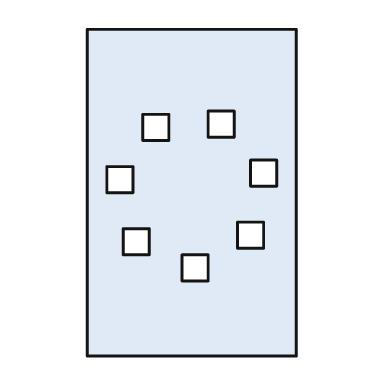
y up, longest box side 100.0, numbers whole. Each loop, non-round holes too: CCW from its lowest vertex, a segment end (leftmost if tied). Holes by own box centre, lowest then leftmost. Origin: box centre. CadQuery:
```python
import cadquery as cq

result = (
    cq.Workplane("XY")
    .moveTo(-32.0, -50.0)
    .lineTo(32.0, -50.0)
    .lineTo(32.0, 50.0)
    .lineTo(-32.0, 50.0)
    .close()
    .moveTo(-3.0, -27.0)
    .lineTo(5.0, -27.0)
    .lineTo(5.0, -19.0)
    .lineTo(-3.0, -19.0)
    .close()
    .moveTo(-21.0, -19.0)
    .lineTo(-13.0, -19.0)
    .lineTo(-13.0, -11.0)
    .lineTo(-21.0, -11.0)
    .close()
    .moveTo(14.0, -17.0)
    .lineTo(22.0, -17.0)
    .lineTo(22.0, -9.0)
    .lineTo(14.0, -9.0)
    .close()
    .moveTo(-26.0, 0.0)
    .lineTo(-18.0, 0.0)
    .lineTo(-18.0, 8.0)
    .lineTo(-26.0, 8.0)
    .close()
    .moveTo(18.0, 2.0)
    .lineTo(26.0, 2.0)
    .lineTo(26.0, 10.0)
    .lineTo(18.0, 10.0)
    .close()
    .moveTo(-15.0, 16.0)
    .lineTo(-7.0, 16.0)
    .lineTo(-7.0, 24.0)
    .lineTo(-15.0, 24.0)
    .close()
    .moveTo(5.0, 17.0)
    .lineTo(13.0, 17.0)
    .lineTo(13.0, 25.0)
    .lineTo(5.0, 25.0)
    .close()
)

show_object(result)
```